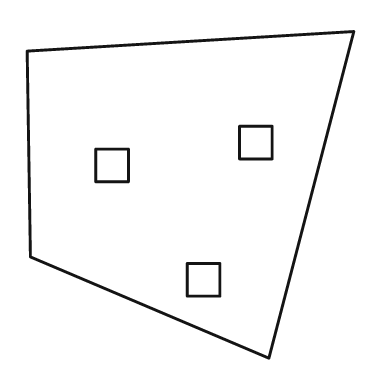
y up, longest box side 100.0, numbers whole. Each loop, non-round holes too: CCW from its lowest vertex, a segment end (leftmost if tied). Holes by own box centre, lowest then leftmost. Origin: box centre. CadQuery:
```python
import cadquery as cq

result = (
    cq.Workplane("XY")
    .moveTo(24.0, -50.0)
    .lineTo(50.0, 50.0)
    .lineTo(-50.0, 44.0)
    .lineTo(-49.0, -19.0)
    .close()
    .moveTo(-1.0, -31.0)
    .lineTo(9.0, -31.0)
    .lineTo(9.0, -21.0)
    .lineTo(-1.0, -21.0)
    .close()
    .moveTo(-29.0, 4.0)
    .lineTo(-19.0, 4.0)
    .lineTo(-19.0, 14.0)
    .lineTo(-29.0, 14.0)
    .close()
    .moveTo(15.0, 11.0)
    .lineTo(25.0, 11.0)
    .lineTo(25.0, 21.0)
    .lineTo(15.0, 21.0)
    .close()
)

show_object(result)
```